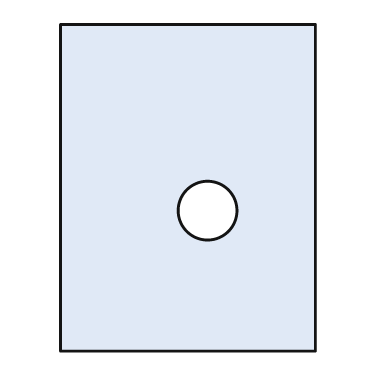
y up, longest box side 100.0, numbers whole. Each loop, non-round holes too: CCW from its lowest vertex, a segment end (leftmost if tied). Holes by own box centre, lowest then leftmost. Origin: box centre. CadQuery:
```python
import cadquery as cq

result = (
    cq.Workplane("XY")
    .moveTo(-39.0, -50.0)
    .lineTo(39.0, -50.0)
    .lineTo(39.0, 50.0)
    .lineTo(-39.0, 50.0)
    .close()
    .moveTo(6.0, -7.0)
    .circle(9.0)
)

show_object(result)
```